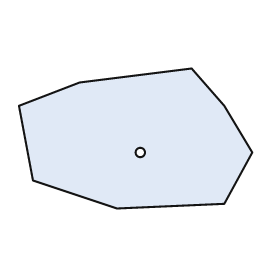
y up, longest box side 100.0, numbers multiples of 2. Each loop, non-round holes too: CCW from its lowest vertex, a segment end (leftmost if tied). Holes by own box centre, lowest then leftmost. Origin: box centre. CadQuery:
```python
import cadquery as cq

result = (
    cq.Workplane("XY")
    .moveTo(-8.0, -30.0)
    .lineTo(38.0, -28.0)
    .lineTo(50.0, -6.0)
    .lineTo(38.0, 14.0)
    .lineTo(24.0, 30.0)
    .lineTo(-24.0, 24.0)
    .lineTo(-50.0, 14.0)
    .lineTo(-44.0, -18.0)
    .close()
    .moveTo(2.0, -6.0)
    .circle(2.0)
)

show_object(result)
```